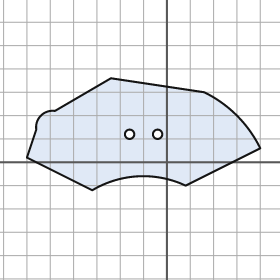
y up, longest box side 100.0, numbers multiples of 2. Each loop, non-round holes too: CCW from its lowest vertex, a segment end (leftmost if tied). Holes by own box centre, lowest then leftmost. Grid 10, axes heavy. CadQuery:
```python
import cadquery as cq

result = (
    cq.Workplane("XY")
    .moveTo(-32.0, -12.0)
    .threePointArc((-12.0, -6.0), (8.0, -10.0))
    .lineTo(40.0, 6.0)
    .threePointArc((30.0, 20.0), (16.0, 30.0))
    .lineTo(-24.0, 36.0)
    .lineTo(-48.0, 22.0)
    .threePointArc((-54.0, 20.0), (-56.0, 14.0))
    .lineTo(-60.0, 2.0)
    .close()
    .moveTo(-16.0, 12.0)
    .circle(2.0)
    .moveTo(-4.0, 12.0)
    .circle(2.0)
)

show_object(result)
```